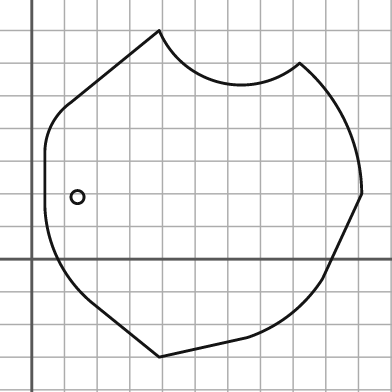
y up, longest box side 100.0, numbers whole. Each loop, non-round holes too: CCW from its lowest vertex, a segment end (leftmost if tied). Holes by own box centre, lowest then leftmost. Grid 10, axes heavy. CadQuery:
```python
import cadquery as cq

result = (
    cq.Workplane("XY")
    .moveTo(39.0, -30.0)
    .lineTo(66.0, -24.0)
    .threePointArc((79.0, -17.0), (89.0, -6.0))
    .lineTo(101.0, 20.0)
    .threePointArc((96.0, 42.0), (82.0, 60.0))
    .threePointArc((58.0, 54.0), (39.0, 70.0))
    .lineTo(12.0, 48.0)
    .threePointArc((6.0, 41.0), (4.0, 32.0))
    .lineTo(4.0, 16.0)
    .threePointArc((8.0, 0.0), (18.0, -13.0))
    .close()
    .moveTo(14.0, 19.0)
    .circle(2.0)
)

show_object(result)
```